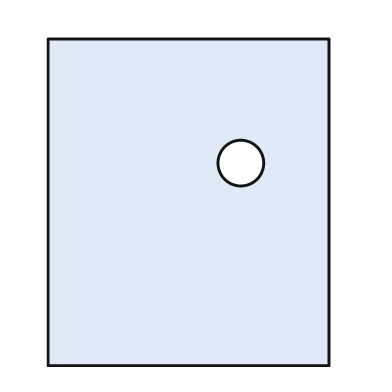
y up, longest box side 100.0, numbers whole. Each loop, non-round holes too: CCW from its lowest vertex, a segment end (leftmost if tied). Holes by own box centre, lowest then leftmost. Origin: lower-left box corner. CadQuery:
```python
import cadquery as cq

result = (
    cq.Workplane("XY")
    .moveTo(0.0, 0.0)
    .lineTo(86.0, 0.0)
    .lineTo(86.0, 100.0)
    .lineTo(0.0, 100.0)
    .close()
    .moveTo(59.0, 62.0)
    .circle(7.0)
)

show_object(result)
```